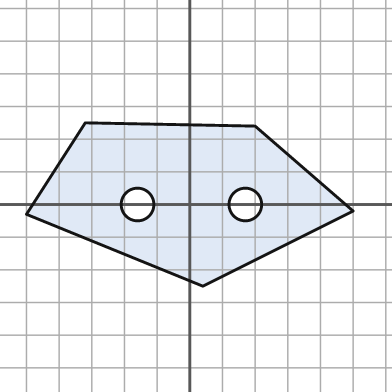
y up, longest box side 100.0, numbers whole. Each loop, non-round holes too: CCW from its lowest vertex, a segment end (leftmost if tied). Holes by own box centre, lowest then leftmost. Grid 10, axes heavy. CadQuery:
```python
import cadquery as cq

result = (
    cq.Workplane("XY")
    .moveTo(4.0, -25.0)
    .lineTo(50.0, -2.0)
    .lineTo(20.0, 24.0)
    .lineTo(-32.0, 25.0)
    .lineTo(-50.0, -3.0)
    .close()
    .moveTo(-16.0, 0.0)
    .circle(5.0)
    .moveTo(17.0, 0.0)
    .circle(5.0)
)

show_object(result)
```